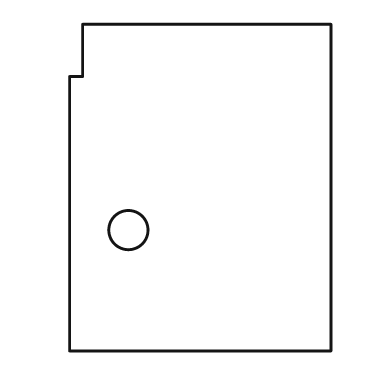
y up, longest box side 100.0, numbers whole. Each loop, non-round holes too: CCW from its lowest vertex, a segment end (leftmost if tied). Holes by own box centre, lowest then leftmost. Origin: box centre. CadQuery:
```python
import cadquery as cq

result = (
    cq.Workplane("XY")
    .moveTo(-40.0, -50.0)
    .lineTo(40.0, -50.0)
    .lineTo(40.0, 50.0)
    .lineTo(-36.0, 50.0)
    .lineTo(-36.0, 34.0)
    .lineTo(-40.0, 34.0)
    .close()
    .moveTo(-22.0, -13.0)
    .circle(6.0)
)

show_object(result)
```